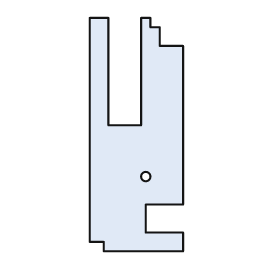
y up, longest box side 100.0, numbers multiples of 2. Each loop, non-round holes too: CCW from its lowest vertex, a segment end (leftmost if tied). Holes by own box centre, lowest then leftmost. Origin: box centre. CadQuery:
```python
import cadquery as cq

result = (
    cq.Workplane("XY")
    .moveTo(-14.0, -50.0)
    .lineTo(20.0, -50.0)
    .lineTo(20.0, -42.0)
    .lineTo(4.0, -42.0)
    .lineTo(4.0, -30.0)
    .lineTo(20.0, -30.0)
    .lineTo(20.0, 38.0)
    .lineTo(10.0, 38.0)
    .lineTo(10.0, 46.0)
    .lineTo(6.0, 46.0)
    .lineTo(6.0, 50.0)
    .lineTo(2.0, 50.0)
    .lineTo(2.0, 4.0)
    .lineTo(-12.0, 4.0)
    .lineTo(-12.0, 50.0)
    .lineTo(-20.0, 50.0)
    .lineTo(-20.0, -46.0)
    .lineTo(-14.0, -46.0)
    .close()
    .moveTo(4.0, -18.0)
    .circle(2.0)
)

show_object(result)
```